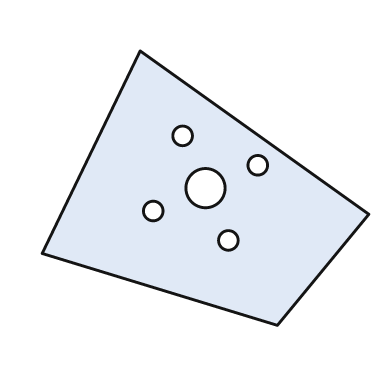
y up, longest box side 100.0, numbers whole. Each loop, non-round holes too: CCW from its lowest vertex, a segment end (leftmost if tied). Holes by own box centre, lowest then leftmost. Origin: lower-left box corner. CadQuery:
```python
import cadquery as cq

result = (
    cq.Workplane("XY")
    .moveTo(72.0, 0.0)
    .lineTo(100.0, 34.0)
    .lineTo(30.0, 84.0)
    .lineTo(0.0, 22.0)
    .close()
    .moveTo(57.0, 26.0)
    .circle(3.0)
    .moveTo(34.0, 35.0)
    .circle(3.0)
    .moveTo(50.0, 42.0)
    .circle(6.0)
    .moveTo(66.0, 49.0)
    .circle(3.0)
    .moveTo(43.0, 58.0)
    .circle(3.0)
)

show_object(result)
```